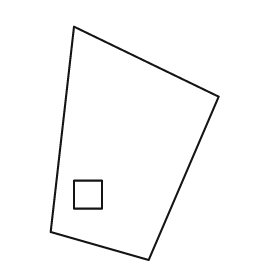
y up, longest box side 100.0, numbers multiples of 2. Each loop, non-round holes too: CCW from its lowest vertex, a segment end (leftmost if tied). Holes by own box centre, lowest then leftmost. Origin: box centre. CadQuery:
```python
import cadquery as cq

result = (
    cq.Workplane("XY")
    .moveTo(6.0, -50.0)
    .lineTo(36.0, 20.0)
    .lineTo(-26.0, 50.0)
    .lineTo(-36.0, -38.0)
    .close()
    .moveTo(-26.0, -28.0)
    .lineTo(-14.0, -28.0)
    .lineTo(-14.0, -16.0)
    .lineTo(-26.0, -16.0)
    .close()
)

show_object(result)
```